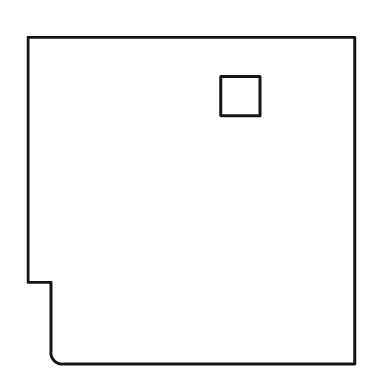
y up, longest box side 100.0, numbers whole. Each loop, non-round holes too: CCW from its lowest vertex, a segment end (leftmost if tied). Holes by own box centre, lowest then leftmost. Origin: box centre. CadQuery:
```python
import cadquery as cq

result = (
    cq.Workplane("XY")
    .moveTo(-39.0, -50.0)
    .lineTo(50.0, -50.0)
    .lineTo(50.0, 50.0)
    .lineTo(-50.0, 50.0)
    .lineTo(-50.0, -25.0)
    .lineTo(-43.0, -25.0)
    .lineTo(-43.0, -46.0)
    .threePointArc((-42.0, -49.0), (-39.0, -50.0))
    .close()
    .moveTo(9.0, 26.0)
    .lineTo(21.0, 26.0)
    .lineTo(21.0, 38.0)
    .lineTo(9.0, 38.0)
    .close()
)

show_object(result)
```